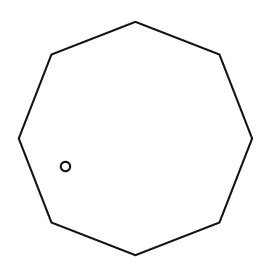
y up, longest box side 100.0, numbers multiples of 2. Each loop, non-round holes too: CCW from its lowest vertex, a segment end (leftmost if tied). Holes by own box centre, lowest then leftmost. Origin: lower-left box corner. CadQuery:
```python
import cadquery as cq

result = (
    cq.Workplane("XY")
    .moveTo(50.0, 0.0)
    .lineTo(86.0, 14.0)
    .lineTo(100.0, 50.0)
    .lineTo(86.0, 86.0)
    .lineTo(50.0, 100.0)
    .lineTo(14.0, 86.0)
    .lineTo(0.0, 50.0)
    .lineTo(14.0, 14.0)
    .close()
    .moveTo(20.0, 38.0)
    .circle(2.0)
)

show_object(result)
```